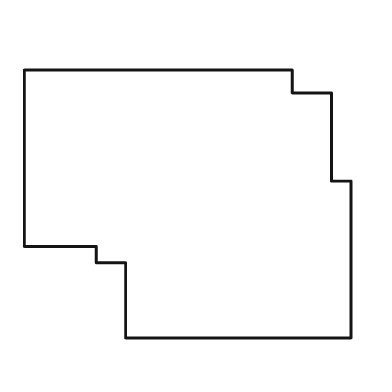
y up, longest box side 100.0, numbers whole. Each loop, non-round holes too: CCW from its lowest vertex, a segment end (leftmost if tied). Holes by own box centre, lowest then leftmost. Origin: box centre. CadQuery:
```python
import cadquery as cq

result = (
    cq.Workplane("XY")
    .moveTo(-19.0, -41.0)
    .lineTo(50.0, -41.0)
    .lineTo(50.0, 7.0)
    .lineTo(44.0, 7.0)
    .lineTo(44.0, 34.0)
    .lineTo(32.0, 34.0)
    .lineTo(32.0, 41.0)
    .lineTo(-50.0, 41.0)
    .lineTo(-50.0, -13.0)
    .lineTo(-28.0, -13.0)
    .lineTo(-28.0, -18.0)
    .lineTo(-19.0, -18.0)
    .close()
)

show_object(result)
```